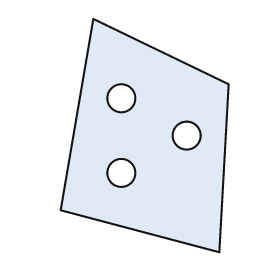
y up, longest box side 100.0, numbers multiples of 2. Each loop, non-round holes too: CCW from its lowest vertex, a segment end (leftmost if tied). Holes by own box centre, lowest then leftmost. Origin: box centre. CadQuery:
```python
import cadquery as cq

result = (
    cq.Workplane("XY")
    .moveTo(32.0, -50.0)
    .lineTo(36.0, 22.0)
    .lineTo(-22.0, 50.0)
    .lineTo(-36.0, -32.0)
    .close()
    .moveTo(-10.0, -16.0)
    .circle(6.0)
    .moveTo(18.0, 0.0)
    .circle(6.0)
    .moveTo(-10.0, 16.0)
    .circle(6.0)
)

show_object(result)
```